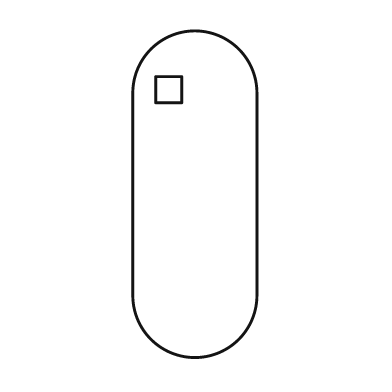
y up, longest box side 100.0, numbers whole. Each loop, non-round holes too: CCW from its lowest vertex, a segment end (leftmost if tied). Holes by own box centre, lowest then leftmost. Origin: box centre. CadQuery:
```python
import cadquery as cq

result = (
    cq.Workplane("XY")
    .moveTo(-19.0, -31.0)
    .threePointArc((0.0, -50.0), (19.0, -31.0))
    .lineTo(19.0, 31.0)
    .threePointArc((0.0, 50.0), (-19.0, 31.0))
    .close()
    .moveTo(-12.0, 28.0)
    .lineTo(-4.0, 28.0)
    .lineTo(-4.0, 36.0)
    .lineTo(-12.0, 36.0)
    .close()
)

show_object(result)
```